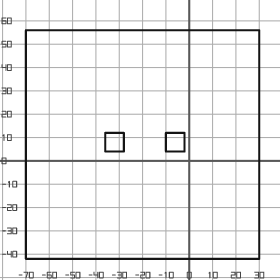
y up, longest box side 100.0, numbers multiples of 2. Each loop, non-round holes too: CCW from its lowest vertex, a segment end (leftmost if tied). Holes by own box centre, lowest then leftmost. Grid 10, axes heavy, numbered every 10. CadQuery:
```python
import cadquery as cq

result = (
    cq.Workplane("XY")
    .moveTo(-70.0, -42.0)
    .lineTo(30.0, -42.0)
    .lineTo(30.0, 56.0)
    .lineTo(-70.0, 56.0)
    .close()
    .moveTo(-36.0, 4.0)
    .lineTo(-28.0, 4.0)
    .lineTo(-28.0, 12.0)
    .lineTo(-36.0, 12.0)
    .close()
    .moveTo(-10.0, 4.0)
    .lineTo(-2.0, 4.0)
    .lineTo(-2.0, 12.0)
    .lineTo(-10.0, 12.0)
    .close()
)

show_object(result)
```